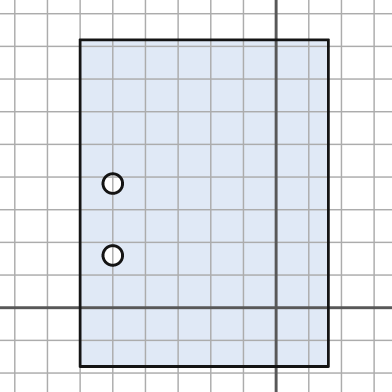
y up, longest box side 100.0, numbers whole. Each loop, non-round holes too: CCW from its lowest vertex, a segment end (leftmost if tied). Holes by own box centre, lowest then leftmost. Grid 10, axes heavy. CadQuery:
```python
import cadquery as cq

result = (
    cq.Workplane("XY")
    .moveTo(-60.0, -18.0)
    .lineTo(16.0, -18.0)
    .lineTo(16.0, 82.0)
    .lineTo(-60.0, 82.0)
    .close()
    .moveTo(-50.0, 16.0)
    .circle(3.0)
    .moveTo(-50.0, 38.0)
    .circle(3.0)
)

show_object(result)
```